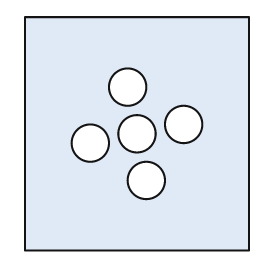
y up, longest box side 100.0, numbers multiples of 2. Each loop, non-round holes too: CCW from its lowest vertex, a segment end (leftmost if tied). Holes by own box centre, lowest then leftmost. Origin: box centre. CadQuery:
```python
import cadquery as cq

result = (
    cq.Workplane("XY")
    .moveTo(-48.0, -50.0)
    .lineTo(48.0, -50.0)
    .lineTo(48.0, 50.0)
    .lineTo(-48.0, 50.0)
    .close()
    .moveTo(4.0, -20.0)
    .circle(8.0)
    .moveTo(-20.0, -4.0)
    .circle(8.0)
    .moveTo(0.0, 0.0)
    .circle(8.0)
    .moveTo(20.0, 4.0)
    .circle(8.0)
    .moveTo(-4.0, 20.0)
    .circle(8.0)
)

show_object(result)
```